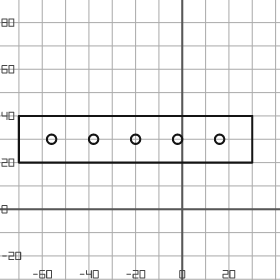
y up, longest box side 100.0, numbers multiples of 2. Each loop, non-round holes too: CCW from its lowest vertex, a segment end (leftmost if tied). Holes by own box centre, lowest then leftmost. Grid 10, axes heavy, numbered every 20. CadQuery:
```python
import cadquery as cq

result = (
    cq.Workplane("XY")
    .moveTo(-70.0, 20.0)
    .lineTo(30.0, 20.0)
    .lineTo(30.0, 40.0)
    .lineTo(-70.0, 40.0)
    .close()
    .moveTo(-56.0, 30.0)
    .circle(2.0)
    .moveTo(-38.0, 30.0)
    .circle(2.0)
    .moveTo(-20.0, 30.0)
    .circle(2.0)
    .moveTo(-2.0, 30.0)
    .circle(2.0)
    .moveTo(16.0, 30.0)
    .circle(2.0)
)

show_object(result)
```